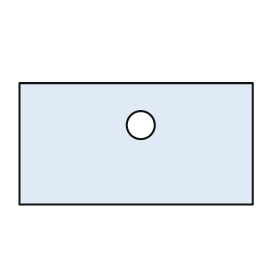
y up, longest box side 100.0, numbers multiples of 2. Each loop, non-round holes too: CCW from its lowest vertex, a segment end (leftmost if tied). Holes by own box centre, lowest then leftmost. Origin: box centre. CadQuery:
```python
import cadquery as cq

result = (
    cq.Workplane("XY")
    .moveTo(-50.0, -26.0)
    .lineTo(50.0, -26.0)
    .lineTo(50.0, 26.0)
    .lineTo(-50.0, 26.0)
    .close()
    .moveTo(2.0, 8.0)
    .circle(6.0)
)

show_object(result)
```